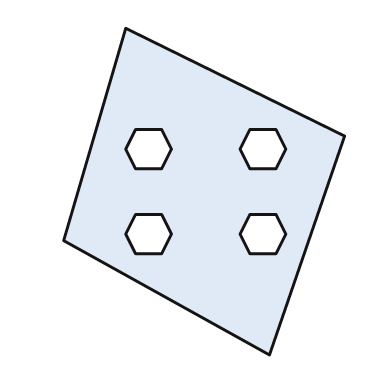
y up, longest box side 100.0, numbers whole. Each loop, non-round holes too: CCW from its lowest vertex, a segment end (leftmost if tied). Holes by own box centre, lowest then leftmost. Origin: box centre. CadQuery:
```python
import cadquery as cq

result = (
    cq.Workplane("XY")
    .moveTo(20.0, -50.0)
    .lineTo(43.0, 17.0)
    .lineTo(-24.0, 50.0)
    .lineTo(-43.0, -15.0)
    .close()
    .moveTo(-21.0, -19.0)
    .lineTo(-13.0, -19.0)
    .lineTo(-10.0, -13.0)
    .lineTo(-13.0, -7.0)
    .lineTo(-21.0, -7.0)
    .lineTo(-24.0, -13.0)
    .close()
    .moveTo(14.0, -19.0)
    .lineTo(22.0, -19.0)
    .lineTo(25.0, -13.0)
    .lineTo(22.0, -7.0)
    .lineTo(14.0, -7.0)
    .lineTo(11.0, -13.0)
    .close()
    .moveTo(-21.0, 7.0)
    .lineTo(-13.0, 7.0)
    .lineTo(-10.0, 13.0)
    .lineTo(-13.0, 19.0)
    .lineTo(-21.0, 19.0)
    .lineTo(-24.0, 13.0)
    .close()
    .moveTo(14.0, 7.0)
    .lineTo(22.0, 7.0)
    .lineTo(25.0, 13.0)
    .lineTo(22.0, 19.0)
    .lineTo(14.0, 19.0)
    .lineTo(11.0, 13.0)
    .close()
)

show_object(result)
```